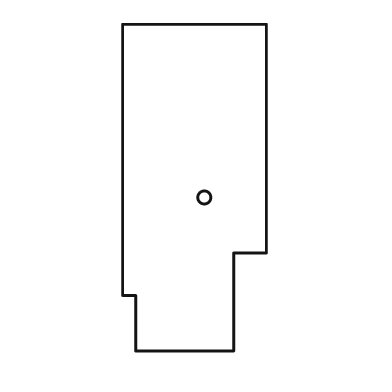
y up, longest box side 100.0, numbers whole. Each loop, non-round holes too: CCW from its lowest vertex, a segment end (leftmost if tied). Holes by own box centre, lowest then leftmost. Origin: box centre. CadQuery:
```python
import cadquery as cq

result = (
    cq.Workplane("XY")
    .moveTo(-18.0, -50.0)
    .lineTo(12.0, -50.0)
    .lineTo(12.0, -20.0)
    .lineTo(22.0, -20.0)
    .lineTo(22.0, 50.0)
    .lineTo(-22.0, 50.0)
    .lineTo(-22.0, -33.0)
    .lineTo(-18.0, -33.0)
    .close()
    .moveTo(3.0, -3.0)
    .circle(2.0)
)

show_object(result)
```